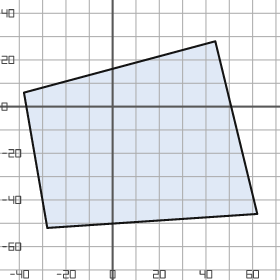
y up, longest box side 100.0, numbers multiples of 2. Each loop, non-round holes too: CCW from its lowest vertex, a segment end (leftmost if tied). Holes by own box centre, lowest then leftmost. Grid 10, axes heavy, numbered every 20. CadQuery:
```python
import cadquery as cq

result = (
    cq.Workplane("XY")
    .moveTo(-28.0, -52.0)
    .lineTo(62.0, -46.0)
    .lineTo(44.0, 28.0)
    .lineTo(-38.0, 6.0)
    .close()
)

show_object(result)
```